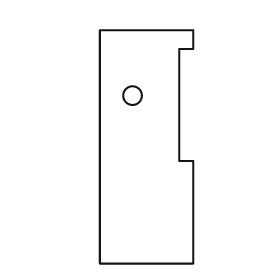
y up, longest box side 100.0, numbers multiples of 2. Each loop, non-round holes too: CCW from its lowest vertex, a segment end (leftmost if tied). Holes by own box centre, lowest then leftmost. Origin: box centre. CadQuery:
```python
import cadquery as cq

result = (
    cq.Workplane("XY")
    .moveTo(-20.0, -50.0)
    .lineTo(20.0, -50.0)
    .lineTo(20.0, -6.0)
    .lineTo(14.0, -6.0)
    .lineTo(14.0, 42.0)
    .lineTo(20.0, 42.0)
    .lineTo(20.0, 50.0)
    .lineTo(-20.0, 50.0)
    .close()
    .moveTo(-6.0, 22.0)
    .circle(4.0)
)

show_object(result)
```